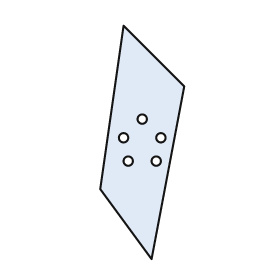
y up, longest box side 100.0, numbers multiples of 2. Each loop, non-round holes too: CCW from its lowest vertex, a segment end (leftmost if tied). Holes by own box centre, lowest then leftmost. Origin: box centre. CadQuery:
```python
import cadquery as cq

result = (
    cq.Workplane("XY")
    .moveTo(4.0, -50.0)
    .lineTo(18.0, 24.0)
    .lineTo(-8.0, 50.0)
    .lineTo(-18.0, -20.0)
    .close()
    .moveTo(-6.0, -8.0)
    .circle(2.0)
    .moveTo(6.0, -8.0)
    .circle(2.0)
    .moveTo(-8.0, 2.0)
    .circle(2.0)
    .moveTo(8.0, 2.0)
    .circle(2.0)
    .moveTo(0.0, 10.0)
    .circle(2.0)
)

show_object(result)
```